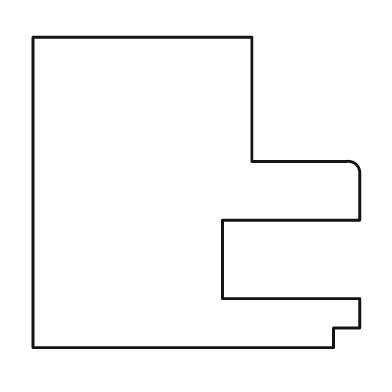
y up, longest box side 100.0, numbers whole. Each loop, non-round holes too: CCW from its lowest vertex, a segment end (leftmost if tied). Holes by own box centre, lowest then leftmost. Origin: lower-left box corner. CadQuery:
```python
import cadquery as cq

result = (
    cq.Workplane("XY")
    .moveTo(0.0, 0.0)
    .lineTo(92.0, 0.0)
    .lineTo(92.0, 6.0)
    .lineTo(100.0, 6.0)
    .lineTo(100.0, 15.0)
    .lineTo(58.0, 15.0)
    .lineTo(58.0, 39.0)
    .lineTo(100.0, 39.0)
    .lineTo(100.0, 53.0)
    .threePointArc((99.0, 56.0), (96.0, 57.0))
    .lineTo(67.0, 57.0)
    .lineTo(67.0, 95.0)
    .lineTo(0.0, 95.0)
    .close()
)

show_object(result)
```